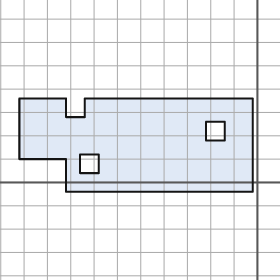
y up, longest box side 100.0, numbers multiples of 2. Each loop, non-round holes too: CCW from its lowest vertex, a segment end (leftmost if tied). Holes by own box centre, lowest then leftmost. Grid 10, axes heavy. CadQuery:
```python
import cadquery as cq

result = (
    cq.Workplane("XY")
    .moveTo(-82.0, -4.0)
    .lineTo(-2.0, -4.0)
    .lineTo(-2.0, 36.0)
    .lineTo(-74.0, 36.0)
    .lineTo(-74.0, 28.0)
    .lineTo(-82.0, 28.0)
    .lineTo(-82.0, 36.0)
    .lineTo(-102.0, 36.0)
    .lineTo(-102.0, 10.0)
    .lineTo(-82.0, 10.0)
    .close()
    .moveTo(-76.0, 4.0)
    .lineTo(-68.0, 4.0)
    .lineTo(-68.0, 12.0)
    .lineTo(-76.0, 12.0)
    .close()
    .moveTo(-22.0, 18.0)
    .lineTo(-14.0, 18.0)
    .lineTo(-14.0, 26.0)
    .lineTo(-22.0, 26.0)
    .close()
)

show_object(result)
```